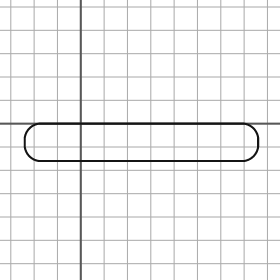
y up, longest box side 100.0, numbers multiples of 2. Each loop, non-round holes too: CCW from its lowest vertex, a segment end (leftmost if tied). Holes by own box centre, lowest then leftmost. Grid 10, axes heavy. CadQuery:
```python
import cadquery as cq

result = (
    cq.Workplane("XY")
    .moveTo(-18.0, -16.0)
    .lineTo(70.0, -16.0)
    .threePointArc((74.0, -14.0), (76.0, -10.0))
    .lineTo(76.0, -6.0)
    .threePointArc((74.0, -2.0), (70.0, 0.0))
    .lineTo(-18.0, 0.0)
    .threePointArc((-22.0, -2.0), (-24.0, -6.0))
    .lineTo(-24.0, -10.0)
    .threePointArc((-22.0, -14.0), (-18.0, -16.0))
    .close()
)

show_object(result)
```